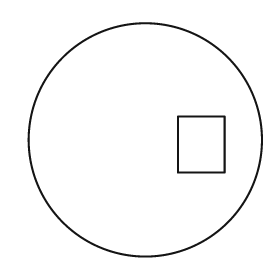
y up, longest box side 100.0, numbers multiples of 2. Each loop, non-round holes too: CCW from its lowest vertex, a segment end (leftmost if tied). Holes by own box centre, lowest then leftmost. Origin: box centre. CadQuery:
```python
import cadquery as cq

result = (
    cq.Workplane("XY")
    .moveTo(0.0, 0.0)
    .circle(50.0)
    .moveTo(14.0, -14.0)
    .lineTo(34.0, -14.0)
    .lineTo(34.0, 10.0)
    .lineTo(14.0, 10.0)
    .close()
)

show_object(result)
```